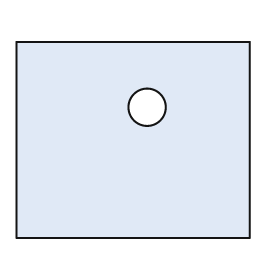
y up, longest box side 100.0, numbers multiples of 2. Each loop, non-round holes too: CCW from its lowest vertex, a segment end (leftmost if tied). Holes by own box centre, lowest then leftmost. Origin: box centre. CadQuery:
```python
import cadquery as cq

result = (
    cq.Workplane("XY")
    .moveTo(-50.0, -42.0)
    .lineTo(50.0, -42.0)
    .lineTo(50.0, 42.0)
    .lineTo(-50.0, 42.0)
    .close()
    .moveTo(6.0, 14.0)
    .circle(8.0)
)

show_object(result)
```